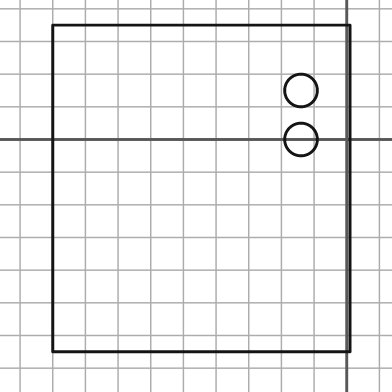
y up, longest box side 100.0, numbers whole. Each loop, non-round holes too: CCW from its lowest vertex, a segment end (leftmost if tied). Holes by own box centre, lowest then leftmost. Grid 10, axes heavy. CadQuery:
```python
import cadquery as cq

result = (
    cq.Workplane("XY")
    .moveTo(-90.0, -65.0)
    .lineTo(1.0, -65.0)
    .lineTo(1.0, 35.0)
    .lineTo(-90.0, 35.0)
    .close()
    .moveTo(-14.0, 0.0)
    .circle(5.0)
    .moveTo(-14.0, 15.0)
    .circle(5.0)
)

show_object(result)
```